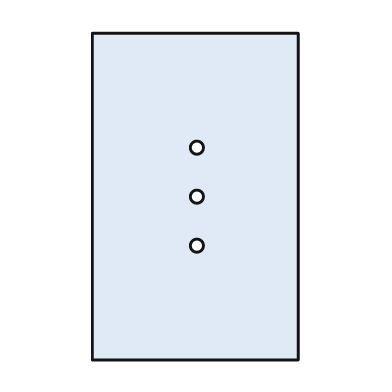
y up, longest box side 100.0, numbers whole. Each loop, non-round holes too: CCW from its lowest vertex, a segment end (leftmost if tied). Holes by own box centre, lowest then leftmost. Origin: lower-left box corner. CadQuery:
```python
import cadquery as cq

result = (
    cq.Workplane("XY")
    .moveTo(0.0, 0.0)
    .lineTo(63.0, 0.0)
    .lineTo(63.0, 100.0)
    .lineTo(0.0, 100.0)
    .close()
    .moveTo(32.0, 35.0)
    .circle(2.0)
    .moveTo(32.0, 50.0)
    .circle(2.0)
    .moveTo(32.0, 65.0)
    .circle(2.0)
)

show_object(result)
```